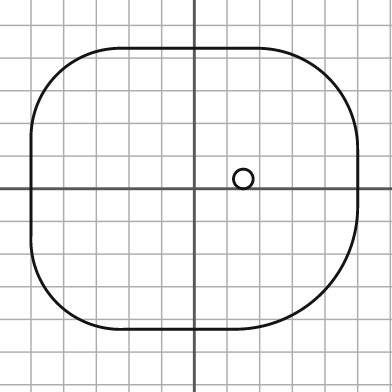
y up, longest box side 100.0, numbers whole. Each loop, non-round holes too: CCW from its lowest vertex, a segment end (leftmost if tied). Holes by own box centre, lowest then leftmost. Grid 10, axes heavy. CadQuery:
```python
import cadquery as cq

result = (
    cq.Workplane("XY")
    .moveTo(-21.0, -43.0)
    .lineTo(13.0, -43.0)
    .threePointArc((39.0, -32.0), (50.0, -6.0))
    .lineTo(50.0, 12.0)
    .threePointArc((41.0, 34.0), (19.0, 43.0))
    .lineTo(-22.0, 43.0)
    .threePointArc((-42.0, 35.0), (-50.0, 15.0))
    .lineTo(-50.0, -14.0)
    .threePointArc((-42.0, -35.0), (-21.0, -43.0))
    .close()
    .moveTo(15.0, 3.0)
    .circle(3.0)
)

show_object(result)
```